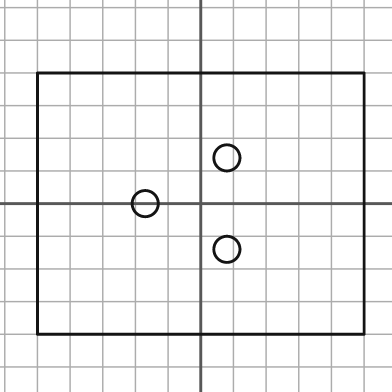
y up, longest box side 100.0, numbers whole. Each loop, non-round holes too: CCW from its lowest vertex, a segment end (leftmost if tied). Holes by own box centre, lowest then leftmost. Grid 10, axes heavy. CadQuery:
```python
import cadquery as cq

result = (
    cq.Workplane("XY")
    .moveTo(-50.0, -40.0)
    .lineTo(50.0, -40.0)
    .lineTo(50.0, 40.0)
    .lineTo(-50.0, 40.0)
    .close()
    .moveTo(8.0, -14.0)
    .circle(4.0)
    .moveTo(-17.0, 0.0)
    .circle(4.0)
    .moveTo(8.0, 14.0)
    .circle(4.0)
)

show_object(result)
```